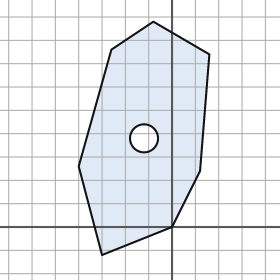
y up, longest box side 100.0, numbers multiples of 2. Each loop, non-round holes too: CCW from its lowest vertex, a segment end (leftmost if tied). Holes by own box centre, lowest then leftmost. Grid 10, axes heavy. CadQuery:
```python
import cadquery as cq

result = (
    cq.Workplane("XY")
    .moveTo(-30.0, -12.0)
    .lineTo(0.0, 0.0)
    .lineTo(12.0, 24.0)
    .lineTo(16.0, 74.0)
    .lineTo(-8.0, 88.0)
    .lineTo(-26.0, 76.0)
    .lineTo(-40.0, 26.0)
    .close()
    .moveTo(-12.0, 38.0)
    .circle(6.0)
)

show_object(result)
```